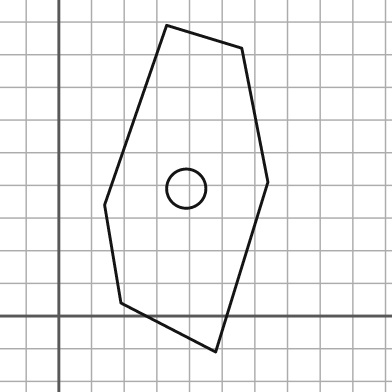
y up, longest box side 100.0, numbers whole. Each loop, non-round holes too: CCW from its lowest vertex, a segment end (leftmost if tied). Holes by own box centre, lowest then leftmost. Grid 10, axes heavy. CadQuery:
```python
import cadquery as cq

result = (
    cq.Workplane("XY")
    .moveTo(48.0, -11.0)
    .lineTo(64.0, 41.0)
    .lineTo(56.0, 82.0)
    .lineTo(33.0, 89.0)
    .lineTo(14.0, 34.0)
    .lineTo(19.0, 4.0)
    .close()
    .moveTo(39.0, 39.0)
    .circle(6.0)
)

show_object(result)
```